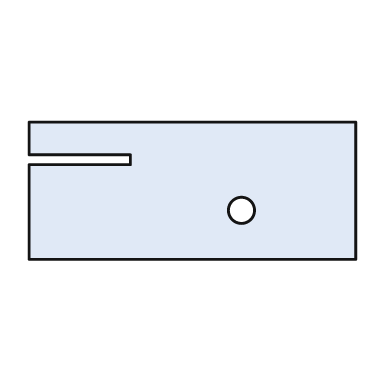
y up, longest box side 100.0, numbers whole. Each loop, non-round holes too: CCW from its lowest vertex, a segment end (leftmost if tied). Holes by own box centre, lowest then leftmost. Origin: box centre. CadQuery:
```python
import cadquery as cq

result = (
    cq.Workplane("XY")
    .moveTo(-50.0, -21.0)
    .lineTo(50.0, -21.0)
    .lineTo(50.0, 21.0)
    .lineTo(-50.0, 21.0)
    .lineTo(-50.0, 11.0)
    .lineTo(-19.0, 11.0)
    .lineTo(-19.0, 8.0)
    .lineTo(-50.0, 8.0)
    .close()
    .moveTo(15.0, -6.0)
    .circle(4.0)
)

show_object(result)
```